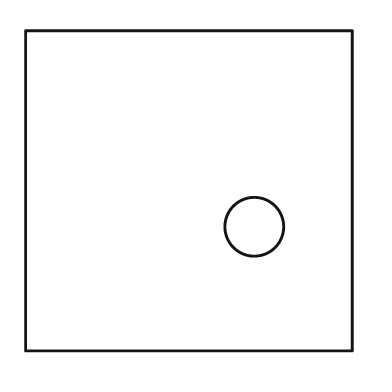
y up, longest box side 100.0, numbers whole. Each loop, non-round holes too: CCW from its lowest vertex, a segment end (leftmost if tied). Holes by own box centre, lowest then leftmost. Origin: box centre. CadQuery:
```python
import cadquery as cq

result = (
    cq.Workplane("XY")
    .moveTo(-50.0, -49.0)
    .lineTo(50.0, -49.0)
    .lineTo(50.0, 49.0)
    .lineTo(-50.0, 49.0)
    .close()
    .moveTo(20.0, -11.0)
    .circle(9.0)
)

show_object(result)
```